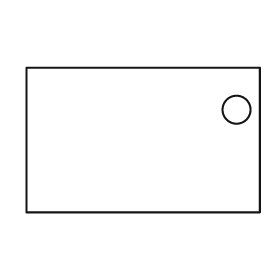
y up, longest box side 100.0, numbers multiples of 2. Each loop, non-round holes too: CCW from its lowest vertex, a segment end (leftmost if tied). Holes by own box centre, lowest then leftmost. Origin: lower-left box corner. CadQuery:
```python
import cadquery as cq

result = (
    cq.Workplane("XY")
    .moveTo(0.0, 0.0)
    .lineTo(100.0, 0.0)
    .lineTo(100.0, 62.0)
    .lineTo(0.0, 62.0)
    .close()
    .moveTo(90.0, 44.0)
    .circle(6.0)
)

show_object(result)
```